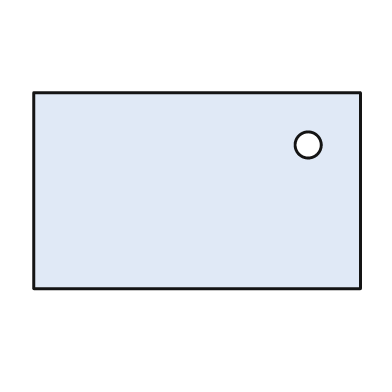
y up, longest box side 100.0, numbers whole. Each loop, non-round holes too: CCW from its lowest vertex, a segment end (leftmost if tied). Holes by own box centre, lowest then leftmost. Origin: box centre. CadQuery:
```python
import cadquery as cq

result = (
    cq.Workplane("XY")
    .moveTo(-50.0, -30.0)
    .lineTo(50.0, -30.0)
    .lineTo(50.0, 30.0)
    .lineTo(-50.0, 30.0)
    .close()
    .moveTo(34.0, 14.0)
    .circle(4.0)
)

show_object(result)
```